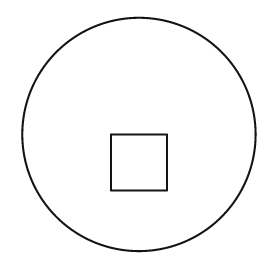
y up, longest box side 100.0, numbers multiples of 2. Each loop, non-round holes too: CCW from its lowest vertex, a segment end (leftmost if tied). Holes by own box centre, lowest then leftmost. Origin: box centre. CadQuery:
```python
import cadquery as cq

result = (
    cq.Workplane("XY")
    .moveTo(0.0, 0.0)
    .circle(50.0)
    .moveTo(-12.0, -24.0)
    .lineTo(12.0, -24.0)
    .lineTo(12.0, 0.0)
    .lineTo(-12.0, 0.0)
    .close()
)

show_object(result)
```